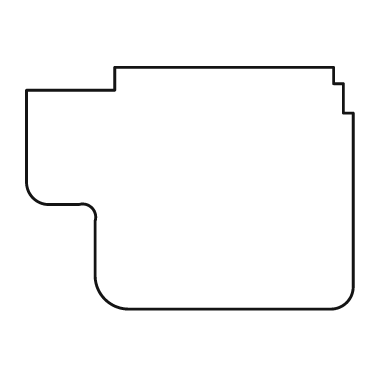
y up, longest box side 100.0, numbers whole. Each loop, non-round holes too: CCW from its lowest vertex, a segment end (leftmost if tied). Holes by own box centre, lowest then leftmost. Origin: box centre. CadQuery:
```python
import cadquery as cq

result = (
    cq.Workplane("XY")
    .moveTo(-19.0, -37.0)
    .lineTo(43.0, -37.0)
    .threePointArc((48.0, -35.0), (50.0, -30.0))
    .lineTo(50.0, 23.0)
    .lineTo(47.0, 23.0)
    .lineTo(47.0, 32.0)
    .lineTo(44.0, 32.0)
    .lineTo(44.0, 37.0)
    .lineTo(-23.0, 37.0)
    .lineTo(-23.0, 30.0)
    .lineTo(-50.0, 30.0)
    .lineTo(-50.0, 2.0)
    .threePointArc((-48.0, -3.0), (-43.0, -5.0))
    .lineTo(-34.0, -5.0)
    .threePointArc((-30.0, -6.0), (-29.0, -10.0))
    .lineTo(-29.0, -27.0)
    .threePointArc((-26.0, -34.0), (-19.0, -37.0))
    .close()
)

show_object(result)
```